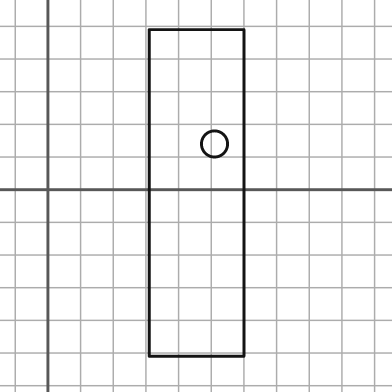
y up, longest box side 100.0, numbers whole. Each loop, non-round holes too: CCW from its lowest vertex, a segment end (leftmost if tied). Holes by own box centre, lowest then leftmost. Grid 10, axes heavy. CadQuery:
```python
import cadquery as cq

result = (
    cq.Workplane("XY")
    .moveTo(31.0, -51.0)
    .lineTo(60.0, -51.0)
    .lineTo(60.0, 49.0)
    .lineTo(31.0, 49.0)
    .close()
    .moveTo(51.0, 14.0)
    .circle(4.0)
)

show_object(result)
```